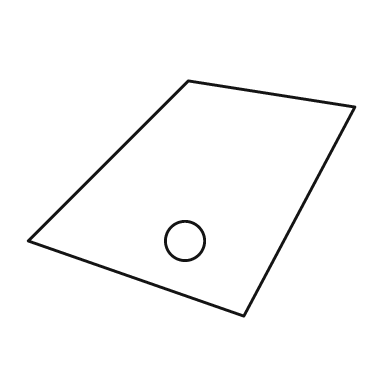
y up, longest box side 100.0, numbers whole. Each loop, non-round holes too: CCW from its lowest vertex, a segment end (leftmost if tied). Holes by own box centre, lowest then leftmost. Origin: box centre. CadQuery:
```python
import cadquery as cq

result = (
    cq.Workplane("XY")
    .moveTo(16.0, -36.0)
    .lineTo(50.0, 28.0)
    .lineTo(-1.0, 36.0)
    .lineTo(-50.0, -13.0)
    .close()
    .moveTo(-2.0, -13.0)
    .circle(6.0)
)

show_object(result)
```